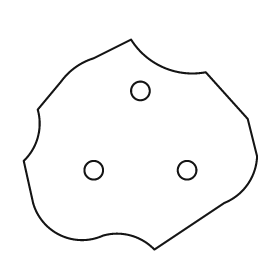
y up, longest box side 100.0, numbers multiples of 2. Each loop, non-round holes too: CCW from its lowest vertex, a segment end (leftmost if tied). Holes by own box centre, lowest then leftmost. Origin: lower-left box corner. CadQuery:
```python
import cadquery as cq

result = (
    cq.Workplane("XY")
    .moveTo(56.0, 0.0)
    .lineTo(86.0, 20.0)
    .threePointArc((96.0, 28.0), (100.0, 40.0))
    .lineTo(96.0, 56.0)
    .lineTo(78.0, 76.0)
    .threePointArc((60.0, 78.0), (46.0, 90.0))
    .lineTo(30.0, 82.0)
    .threePointArc((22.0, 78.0), (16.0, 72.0))
    .lineTo(6.0, 60.0)
    .threePointArc((6.0, 48.0), (0.0, 38.0))
    .lineTo(4.0, 20.0)
    .threePointArc((16.0, 6.0), (34.0, 6.0))
    .threePointArc((46.0, 6.0), (56.0, 0.0))
    .close()
    .moveTo(30.0, 34.0)
    .circle(4.0)
    .moveTo(70.0, 34.0)
    .circle(4.0)
    .moveTo(50.0, 68.0)
    .circle(4.0)
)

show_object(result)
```